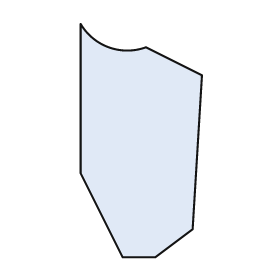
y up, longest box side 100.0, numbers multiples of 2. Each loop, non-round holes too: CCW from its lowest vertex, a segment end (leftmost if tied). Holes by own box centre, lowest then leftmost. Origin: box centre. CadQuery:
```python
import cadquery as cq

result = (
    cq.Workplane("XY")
    .moveTo(-8.0, -50.0)
    .lineTo(6.0, -50.0)
    .lineTo(22.0, -38.0)
    .lineTo(26.0, 28.0)
    .lineTo(2.0, 40.0)
    .threePointArc((-14.0, 40.0), (-26.0, 50.0))
    .lineTo(-26.0, -14.0)
    .close()
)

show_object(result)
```